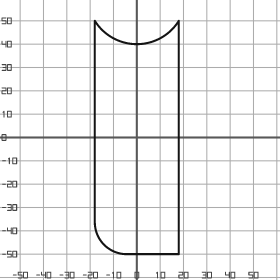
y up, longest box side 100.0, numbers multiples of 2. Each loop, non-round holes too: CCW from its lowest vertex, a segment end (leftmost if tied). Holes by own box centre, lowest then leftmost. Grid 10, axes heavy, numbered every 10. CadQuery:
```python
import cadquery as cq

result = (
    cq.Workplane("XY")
    .moveTo(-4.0, -50.0)
    .lineTo(18.0, -50.0)
    .lineTo(18.0, 50.0)
    .threePointArc((0.0, 40.0), (-18.0, 50.0))
    .lineTo(-18.0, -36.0)
    .threePointArc((-14.0, -46.0), (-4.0, -50.0))
    .close()
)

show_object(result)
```